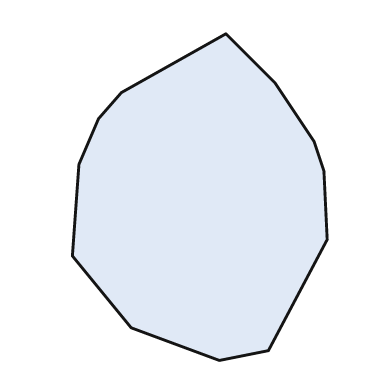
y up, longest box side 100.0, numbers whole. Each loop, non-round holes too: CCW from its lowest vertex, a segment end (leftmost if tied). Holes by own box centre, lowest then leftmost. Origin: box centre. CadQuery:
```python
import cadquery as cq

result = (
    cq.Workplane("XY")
    .moveTo(6.0, -50.0)
    .lineTo(21.0, -47.0)
    .lineTo(39.0, -13.0)
    .lineTo(38.0, 8.0)
    .lineTo(35.0, 17.0)
    .lineTo(23.0, 35.0)
    .lineTo(8.0, 50.0)
    .lineTo(-24.0, 32.0)
    .lineTo(-31.0, 24.0)
    .lineTo(-37.0, 10.0)
    .lineTo(-39.0, -18.0)
    .lineTo(-21.0, -40.0)
    .close()
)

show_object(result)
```